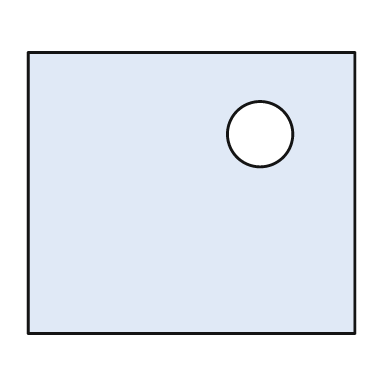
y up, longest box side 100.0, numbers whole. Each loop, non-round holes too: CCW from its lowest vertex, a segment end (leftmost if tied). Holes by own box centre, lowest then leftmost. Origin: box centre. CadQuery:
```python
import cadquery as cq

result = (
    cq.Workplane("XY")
    .moveTo(-50.0, -43.0)
    .lineTo(50.0, -43.0)
    .lineTo(50.0, 43.0)
    .lineTo(-50.0, 43.0)
    .close()
    .moveTo(21.0, 18.0)
    .circle(10.0)
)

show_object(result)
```